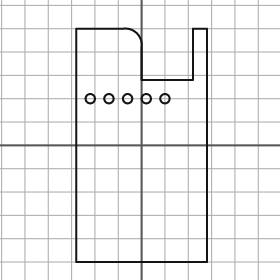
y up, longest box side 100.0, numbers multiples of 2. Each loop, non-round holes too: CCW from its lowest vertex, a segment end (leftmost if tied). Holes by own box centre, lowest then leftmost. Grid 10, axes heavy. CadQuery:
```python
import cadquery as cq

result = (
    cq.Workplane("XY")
    .moveTo(-28.0, -50.0)
    .lineTo(28.0, -50.0)
    .lineTo(28.0, 50.0)
    .lineTo(22.0, 50.0)
    .lineTo(22.0, 28.0)
    .lineTo(0.0, 28.0)
    .lineTo(0.0, 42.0)
    .threePointArc((-2.0, 48.0), (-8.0, 50.0))
    .lineTo(-28.0, 50.0)
    .close()
    .moveTo(-22.0, 20.0)
    .circle(2.0)
    .moveTo(-14.0, 20.0)
    .circle(2.0)
    .moveTo(-6.0, 20.0)
    .circle(2.0)
    .moveTo(2.0, 20.0)
    .circle(2.0)
    .moveTo(10.0, 20.0)
    .circle(2.0)
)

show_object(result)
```